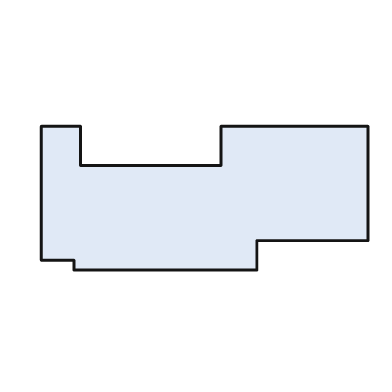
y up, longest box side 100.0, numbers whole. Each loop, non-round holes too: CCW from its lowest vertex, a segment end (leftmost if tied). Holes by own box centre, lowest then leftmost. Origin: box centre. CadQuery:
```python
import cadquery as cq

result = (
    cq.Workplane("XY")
    .moveTo(-40.0, -22.0)
    .lineTo(16.0, -22.0)
    .lineTo(16.0, -13.0)
    .lineTo(50.0, -13.0)
    .lineTo(50.0, 22.0)
    .lineTo(5.0, 22.0)
    .lineTo(5.0, 10.0)
    .lineTo(-38.0, 10.0)
    .lineTo(-38.0, 22.0)
    .lineTo(-50.0, 22.0)
    .lineTo(-50.0, -19.0)
    .lineTo(-40.0, -19.0)
    .close()
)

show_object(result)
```